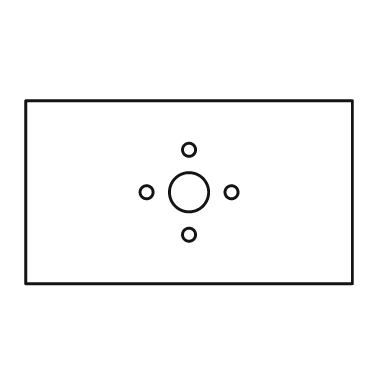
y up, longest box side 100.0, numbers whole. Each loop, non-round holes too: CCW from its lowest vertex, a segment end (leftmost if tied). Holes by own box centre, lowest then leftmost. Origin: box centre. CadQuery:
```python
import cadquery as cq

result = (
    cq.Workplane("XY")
    .moveTo(-50.0, -28.0)
    .lineTo(50.0, -28.0)
    .lineTo(50.0, 28.0)
    .lineTo(-50.0, 28.0)
    .close()
    .moveTo(0.0, -13.0)
    .circle(2.0)
    .moveTo(-13.0, 0.0)
    .circle(2.0)
    .moveTo(0.0, 0.0)
    .circle(6.0)
    .moveTo(13.0, 0.0)
    .circle(2.0)
    .moveTo(0.0, 13.0)
    .circle(2.0)
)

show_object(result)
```